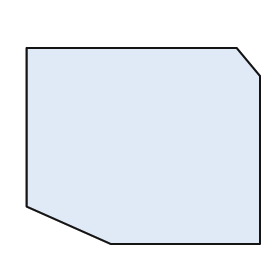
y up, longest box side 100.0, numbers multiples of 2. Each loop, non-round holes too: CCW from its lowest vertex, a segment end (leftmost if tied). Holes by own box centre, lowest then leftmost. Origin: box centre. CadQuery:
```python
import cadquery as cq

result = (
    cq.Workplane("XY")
    .moveTo(-14.0, -42.0)
    .lineTo(50.0, -42.0)
    .lineTo(50.0, 30.0)
    .lineTo(40.0, 42.0)
    .lineTo(-50.0, 42.0)
    .lineTo(-50.0, -26.0)
    .close()
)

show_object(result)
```